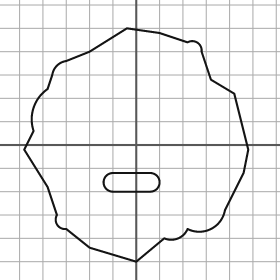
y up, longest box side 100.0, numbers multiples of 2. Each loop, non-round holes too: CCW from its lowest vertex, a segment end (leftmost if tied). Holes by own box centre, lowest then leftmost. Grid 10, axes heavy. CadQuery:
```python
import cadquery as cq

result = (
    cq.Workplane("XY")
    .moveTo(0.0, -50.0)
    .lineTo(12.0, -40.0)
    .threePointArc((18.0, -40.0), (22.0, -36.0))
    .threePointArc((32.0, -36.0), (38.0, -28.0))
    .lineTo(46.0, -12.0)
    .lineTo(48.0, -2.0)
    .lineTo(42.0, 22.0)
    .lineTo(32.0, 28.0)
    .lineTo(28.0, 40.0)
    .threePointArc((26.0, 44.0), (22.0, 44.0))
    .lineTo(10.0, 48.0)
    .lineTo(-4.0, 50.0)
    .lineTo(-20.0, 40.0)
    .lineTo(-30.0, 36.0)
    .threePointArc((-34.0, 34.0), (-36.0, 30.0))
    .lineTo(-38.0, 24.0)
    .threePointArc((-44.0, 16.0), (-44.0, 6.0))
    .lineTo(-48.0, -2.0)
    .lineTo(-38.0, -18.0)
    .lineTo(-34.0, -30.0)
    .threePointArc((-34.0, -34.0), (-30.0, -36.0))
    .lineTo(-20.0, -44.0)
    .close()
    .moveTo(-10.0, -20.0)
    .lineTo(6.0, -20.0)
    .threePointArc((10.0, -16.0), (6.0, -12.0))
    .lineTo(-10.0, -12.0)
    .threePointArc((-14.0, -16.0), (-10.0, -20.0))
    .close()
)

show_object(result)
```